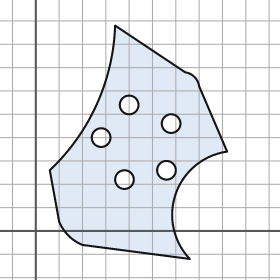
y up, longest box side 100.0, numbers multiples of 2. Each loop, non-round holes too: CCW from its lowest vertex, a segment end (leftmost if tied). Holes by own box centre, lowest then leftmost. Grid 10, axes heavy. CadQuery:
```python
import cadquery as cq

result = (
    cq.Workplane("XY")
    .moveTo(66.0, -12.0)
    .threePointArc((60.0, 16.0), (82.0, 34.0))
    .lineTo(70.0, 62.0)
    .threePointArc((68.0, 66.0), (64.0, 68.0))
    .lineTo(34.0, 88.0)
    .threePointArc((26.0, 54.0), (6.0, 26.0))
    .lineTo(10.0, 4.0)
    .threePointArc((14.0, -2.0), (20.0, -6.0))
    .close()
    .moveTo(38.0, 22.0)
    .circle(4.0)
    .moveTo(56.0, 26.0)
    .circle(4.0)
    .moveTo(28.0, 40.0)
    .circle(4.0)
    .moveTo(58.0, 46.0)
    .circle(4.0)
    .moveTo(40.0, 54.0)
    .circle(4.0)
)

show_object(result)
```